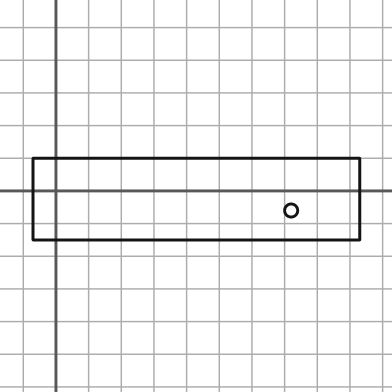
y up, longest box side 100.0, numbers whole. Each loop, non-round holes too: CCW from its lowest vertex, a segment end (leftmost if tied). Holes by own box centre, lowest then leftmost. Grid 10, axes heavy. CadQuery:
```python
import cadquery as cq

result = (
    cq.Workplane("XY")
    .moveTo(-7.0, -15.0)
    .lineTo(93.0, -15.0)
    .lineTo(93.0, 10.0)
    .lineTo(-7.0, 10.0)
    .close()
    .moveTo(72.0, -6.0)
    .circle(2.0)
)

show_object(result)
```